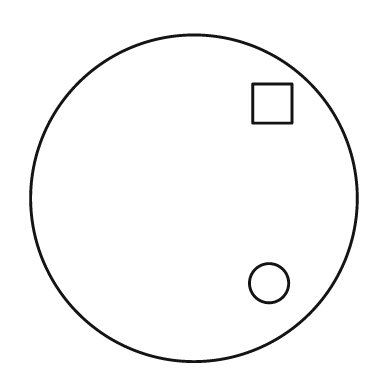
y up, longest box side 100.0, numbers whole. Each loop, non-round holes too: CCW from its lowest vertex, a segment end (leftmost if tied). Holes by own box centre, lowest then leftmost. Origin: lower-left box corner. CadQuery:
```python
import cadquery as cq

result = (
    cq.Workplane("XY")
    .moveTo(50.0, 50.0)
    .circle(50.0)
    .moveTo(73.0, 24.0)
    .circle(6.0)
    .moveTo(68.0, 73.0)
    .lineTo(80.0, 73.0)
    .lineTo(80.0, 85.0)
    .lineTo(68.0, 85.0)
    .close()
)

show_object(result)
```